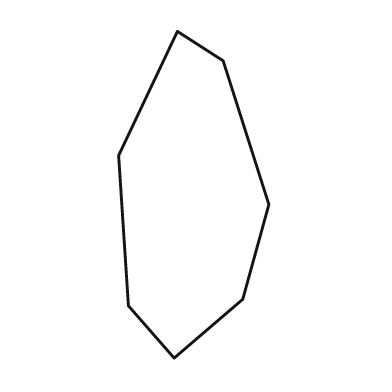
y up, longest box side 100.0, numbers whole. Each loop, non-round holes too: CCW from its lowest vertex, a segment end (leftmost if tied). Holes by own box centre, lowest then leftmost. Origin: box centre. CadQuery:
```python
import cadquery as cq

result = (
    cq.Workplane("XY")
    .moveTo(-6.0, -50.0)
    .lineTo(15.0, -32.0)
    .lineTo(23.0, -3.0)
    .lineTo(9.0, 41.0)
    .lineTo(-5.0, 50.0)
    .lineTo(-23.0, 12.0)
    .lineTo(-20.0, -34.0)
    .close()
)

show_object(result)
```